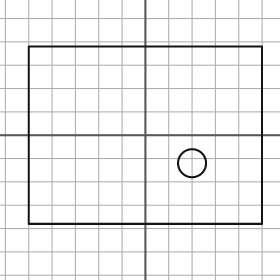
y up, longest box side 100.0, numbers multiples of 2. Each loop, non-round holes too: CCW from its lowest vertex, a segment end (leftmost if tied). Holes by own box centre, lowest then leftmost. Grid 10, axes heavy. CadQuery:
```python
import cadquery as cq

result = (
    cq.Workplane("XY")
    .moveTo(-50.0, -38.0)
    .lineTo(50.0, -38.0)
    .lineTo(50.0, 38.0)
    .lineTo(-50.0, 38.0)
    .close()
    .moveTo(20.0, -12.0)
    .circle(6.0)
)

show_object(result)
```